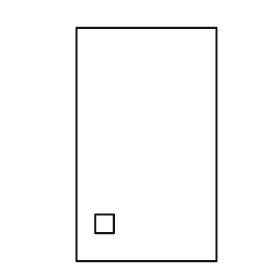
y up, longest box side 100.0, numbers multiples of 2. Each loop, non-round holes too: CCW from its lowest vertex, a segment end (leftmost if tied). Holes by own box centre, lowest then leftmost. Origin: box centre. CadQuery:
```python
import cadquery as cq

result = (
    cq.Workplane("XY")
    .moveTo(-30.0, -50.0)
    .lineTo(30.0, -50.0)
    .lineTo(30.0, 50.0)
    .lineTo(-30.0, 50.0)
    .close()
    .moveTo(-22.0, -38.0)
    .lineTo(-14.0, -38.0)
    .lineTo(-14.0, -30.0)
    .lineTo(-22.0, -30.0)
    .close()
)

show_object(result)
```